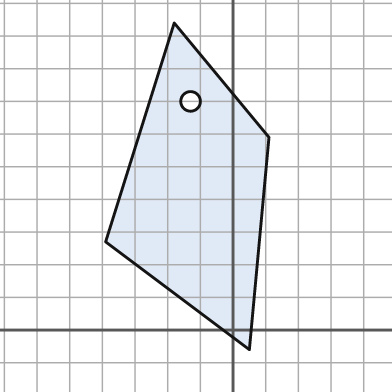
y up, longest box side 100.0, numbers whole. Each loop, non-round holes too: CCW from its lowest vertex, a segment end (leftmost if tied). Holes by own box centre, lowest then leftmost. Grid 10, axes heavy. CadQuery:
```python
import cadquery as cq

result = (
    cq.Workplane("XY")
    .moveTo(5.0, -6.0)
    .lineTo(11.0, 59.0)
    .lineTo(-18.0, 94.0)
    .lineTo(-39.0, 27.0)
    .close()
    .moveTo(-13.0, 70.0)
    .circle(3.0)
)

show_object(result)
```